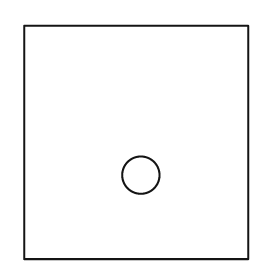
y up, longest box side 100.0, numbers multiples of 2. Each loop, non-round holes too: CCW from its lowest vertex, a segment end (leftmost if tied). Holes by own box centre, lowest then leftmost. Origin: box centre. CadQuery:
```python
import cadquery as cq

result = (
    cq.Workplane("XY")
    .moveTo(-48.0, -50.0)
    .lineTo(48.0, -50.0)
    .lineTo(48.0, 50.0)
    .lineTo(-48.0, 50.0)
    .close()
    .moveTo(2.0, -14.0)
    .circle(8.0)
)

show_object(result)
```